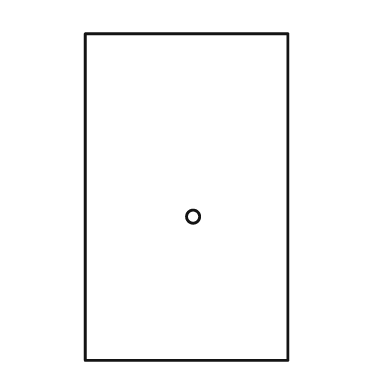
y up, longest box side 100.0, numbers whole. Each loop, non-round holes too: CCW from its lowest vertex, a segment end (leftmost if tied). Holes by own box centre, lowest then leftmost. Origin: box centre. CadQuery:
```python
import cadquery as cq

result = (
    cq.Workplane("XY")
    .moveTo(-31.0, -50.0)
    .lineTo(31.0, -50.0)
    .lineTo(31.0, 50.0)
    .lineTo(-31.0, 50.0)
    .close()
    .moveTo(2.0, -6.0)
    .circle(2.0)
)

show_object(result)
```